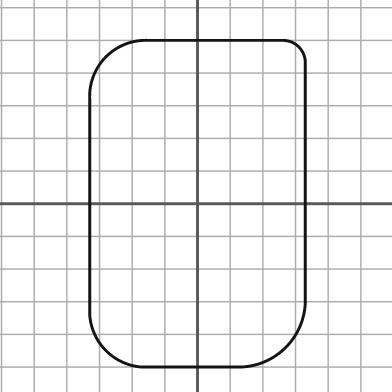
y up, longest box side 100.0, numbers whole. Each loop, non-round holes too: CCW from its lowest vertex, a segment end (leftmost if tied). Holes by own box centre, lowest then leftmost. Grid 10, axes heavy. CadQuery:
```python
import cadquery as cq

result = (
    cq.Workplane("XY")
    .moveTo(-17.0, -50.0)
    .lineTo(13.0, -50.0)
    .threePointArc((27.0, -44.0), (33.0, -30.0))
    .lineTo(33.0, 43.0)
    .threePointArc((31.0, 48.0), (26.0, 50.0))
    .lineTo(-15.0, 50.0)
    .threePointArc((-28.0, 45.0), (-33.0, 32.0))
    .lineTo(-33.0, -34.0)
    .threePointArc((-28.0, -45.0), (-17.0, -50.0))
    .close()
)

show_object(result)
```